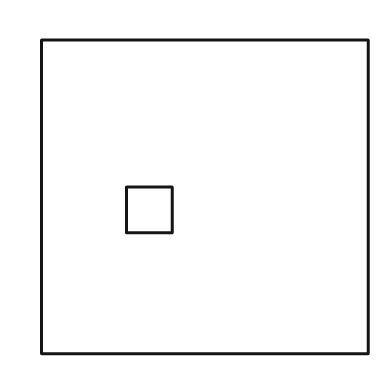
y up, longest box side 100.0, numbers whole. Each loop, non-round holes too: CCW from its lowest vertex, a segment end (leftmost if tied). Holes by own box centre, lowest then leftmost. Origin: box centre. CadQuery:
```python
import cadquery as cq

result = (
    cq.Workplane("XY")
    .moveTo(-50.0, -48.0)
    .lineTo(50.0, -48.0)
    .lineTo(50.0, 48.0)
    .lineTo(-50.0, 48.0)
    .close()
    .moveTo(-24.0, -11.0)
    .lineTo(-10.0, -11.0)
    .lineTo(-10.0, 3.0)
    .lineTo(-24.0, 3.0)
    .close()
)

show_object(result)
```